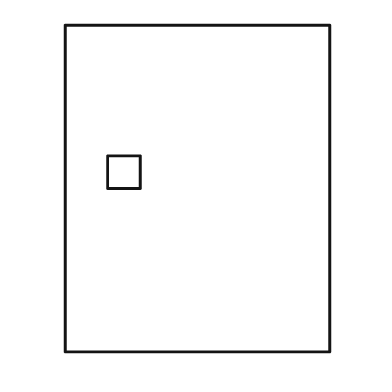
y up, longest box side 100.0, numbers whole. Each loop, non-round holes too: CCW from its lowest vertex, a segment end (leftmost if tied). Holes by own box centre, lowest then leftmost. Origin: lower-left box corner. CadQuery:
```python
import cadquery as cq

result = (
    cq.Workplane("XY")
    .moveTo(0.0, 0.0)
    .lineTo(81.0, 0.0)
    .lineTo(81.0, 100.0)
    .lineTo(0.0, 100.0)
    .close()
    .moveTo(13.0, 50.0)
    .lineTo(23.0, 50.0)
    .lineTo(23.0, 60.0)
    .lineTo(13.0, 60.0)
    .close()
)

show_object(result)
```